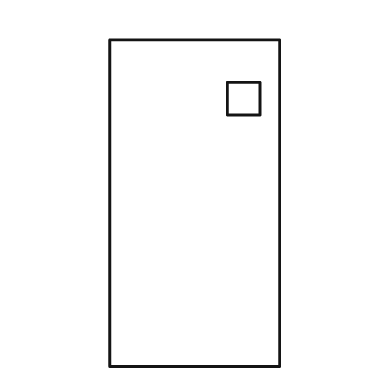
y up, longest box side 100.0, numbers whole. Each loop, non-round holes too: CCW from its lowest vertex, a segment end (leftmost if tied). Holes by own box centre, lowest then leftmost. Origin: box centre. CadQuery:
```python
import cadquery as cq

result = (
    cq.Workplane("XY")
    .moveTo(-26.0, -50.0)
    .lineTo(26.0, -50.0)
    .lineTo(26.0, 50.0)
    .lineTo(-26.0, 50.0)
    .close()
    .moveTo(10.0, 27.0)
    .lineTo(20.0, 27.0)
    .lineTo(20.0, 37.0)
    .lineTo(10.0, 37.0)
    .close()
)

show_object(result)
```